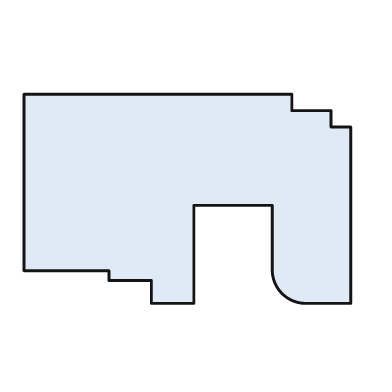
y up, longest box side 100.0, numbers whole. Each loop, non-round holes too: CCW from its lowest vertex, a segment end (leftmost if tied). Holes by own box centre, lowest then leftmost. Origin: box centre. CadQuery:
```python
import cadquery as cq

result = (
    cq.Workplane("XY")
    .moveTo(-11.0, -32.0)
    .lineTo(2.0, -32.0)
    .lineTo(2.0, -2.0)
    .lineTo(26.0, -2.0)
    .lineTo(26.0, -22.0)
    .threePointArc((29.0, -29.0), (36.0, -32.0))
    .lineTo(50.0, -32.0)
    .lineTo(50.0, 22.0)
    .lineTo(44.0, 22.0)
    .lineTo(44.0, 27.0)
    .lineTo(32.0, 27.0)
    .lineTo(32.0, 32.0)
    .lineTo(-50.0, 32.0)
    .lineTo(-50.0, -22.0)
    .lineTo(-24.0, -22.0)
    .lineTo(-24.0, -25.0)
    .lineTo(-11.0, -25.0)
    .close()
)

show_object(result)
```